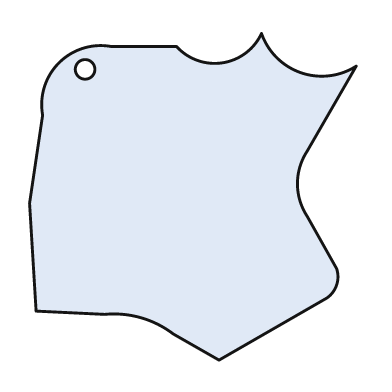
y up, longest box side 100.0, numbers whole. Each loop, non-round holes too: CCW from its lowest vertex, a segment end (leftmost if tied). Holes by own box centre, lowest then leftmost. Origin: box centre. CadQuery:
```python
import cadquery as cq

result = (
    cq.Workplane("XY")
    .moveTo(8.0, -50.0)
    .lineTo(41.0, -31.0)
    .threePointArc((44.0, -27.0), (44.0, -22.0))
    .lineTo(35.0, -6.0)
    .threePointArc((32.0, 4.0), (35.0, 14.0))
    .lineTo(50.0, 40.0)
    .threePointArc((33.0, 38.0), (21.0, 50.0))
    .threePointArc((9.0, 41.0), (-5.0, 46.0))
    .lineTo(-25.0, 46.0)
    .threePointArc((-41.0, 41.0), (-46.0, 25.0))
    .lineTo(-50.0, -2.0)
    .lineTo(-48.0, -35.0)
    .lineTo(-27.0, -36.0)
    .threePointArc((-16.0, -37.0), (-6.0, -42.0))
    .close()
    .moveTo(-33.0, 39.0)
    .circle(3.0)
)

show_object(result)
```